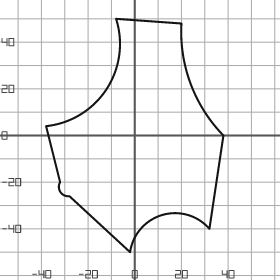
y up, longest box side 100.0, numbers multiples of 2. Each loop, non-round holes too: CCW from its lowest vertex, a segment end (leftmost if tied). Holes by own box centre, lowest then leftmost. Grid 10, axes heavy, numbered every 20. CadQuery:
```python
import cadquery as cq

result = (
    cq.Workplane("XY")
    .moveTo(-2.0, -50.0)
    .threePointArc((12.0, -34.0), (32.0, -40.0))
    .lineTo(38.0, 0.0)
    .threePointArc((24.0, 22.0), (20.0, 48.0))
    .lineTo(-8.0, 50.0)
    .threePointArc((-12.0, 20.0), (-38.0, 4.0))
    .lineTo(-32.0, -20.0)
    .threePointArc((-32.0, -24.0), (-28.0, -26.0))
    .close()
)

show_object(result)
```